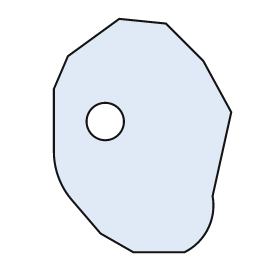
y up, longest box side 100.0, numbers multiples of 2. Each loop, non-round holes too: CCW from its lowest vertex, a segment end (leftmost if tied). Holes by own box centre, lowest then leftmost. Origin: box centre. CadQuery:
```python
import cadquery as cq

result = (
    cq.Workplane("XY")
    .moveTo(-4.0, -50.0)
    .lineTo(18.0, -50.0)
    .threePointArc((28.0, -40.0), (30.0, -26.0))
    .lineTo(38.0, 10.0)
    .lineTo(26.0, 32.0)
    .lineTo(10.0, 48.0)
    .lineTo(-10.0, 50.0)
    .lineTo(-32.0, 34.0)
    .lineTo(-38.0, 20.0)
    .lineTo(-38.0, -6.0)
    .threePointArc((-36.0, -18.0), (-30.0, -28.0))
    .lineTo(-18.0, -42.0)
    .close()
    .moveTo(-16.0, 6.0)
    .circle(8.0)
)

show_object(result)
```